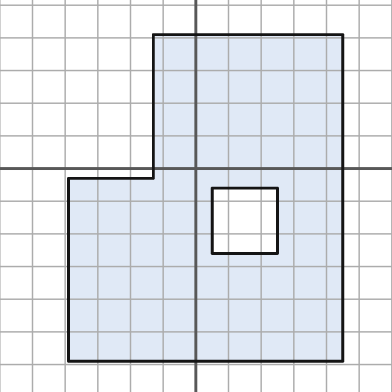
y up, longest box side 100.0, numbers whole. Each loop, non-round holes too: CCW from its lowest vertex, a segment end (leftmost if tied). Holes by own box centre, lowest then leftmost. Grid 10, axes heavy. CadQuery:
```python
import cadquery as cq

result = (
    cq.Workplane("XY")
    .moveTo(-39.0, -59.0)
    .lineTo(45.0, -59.0)
    .lineTo(45.0, 41.0)
    .lineTo(-13.0, 41.0)
    .lineTo(-13.0, -3.0)
    .lineTo(-39.0, -3.0)
    .close()
    .moveTo(5.0, -26.0)
    .lineTo(25.0, -26.0)
    .lineTo(25.0, -6.0)
    .lineTo(5.0, -6.0)
    .close()
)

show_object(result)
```